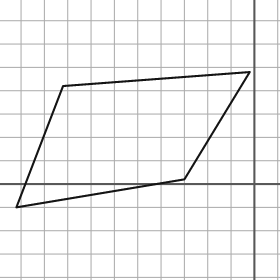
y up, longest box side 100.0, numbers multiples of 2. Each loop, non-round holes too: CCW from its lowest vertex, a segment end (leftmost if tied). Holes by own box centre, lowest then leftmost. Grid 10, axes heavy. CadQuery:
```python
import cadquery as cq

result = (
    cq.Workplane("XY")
    .moveTo(-102.0, -10.0)
    .lineTo(-30.0, 2.0)
    .lineTo(-2.0, 48.0)
    .lineTo(-82.0, 42.0)
    .close()
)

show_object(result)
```